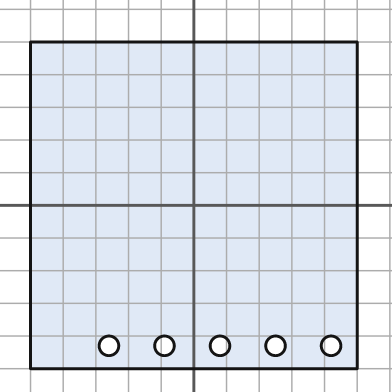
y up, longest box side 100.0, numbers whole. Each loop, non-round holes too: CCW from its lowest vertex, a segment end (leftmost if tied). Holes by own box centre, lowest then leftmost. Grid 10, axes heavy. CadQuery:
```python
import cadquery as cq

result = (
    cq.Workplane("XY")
    .moveTo(-50.0, -50.0)
    .lineTo(50.0, -50.0)
    .lineTo(50.0, 50.0)
    .lineTo(-50.0, 50.0)
    .close()
    .moveTo(-26.0, -43.0)
    .circle(3.0)
    .moveTo(-9.0, -43.0)
    .circle(3.0)
    .moveTo(8.0, -43.0)
    .circle(3.0)
    .moveTo(25.0, -43.0)
    .circle(3.0)
    .moveTo(42.0, -43.0)
    .circle(3.0)
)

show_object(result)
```